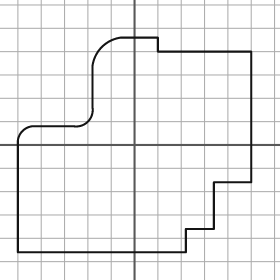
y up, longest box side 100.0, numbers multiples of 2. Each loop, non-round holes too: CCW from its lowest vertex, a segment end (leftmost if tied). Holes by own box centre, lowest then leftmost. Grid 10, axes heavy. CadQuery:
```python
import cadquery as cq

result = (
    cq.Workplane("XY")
    .moveTo(-50.0, -46.0)
    .lineTo(22.0, -46.0)
    .lineTo(22.0, -36.0)
    .lineTo(34.0, -36.0)
    .lineTo(34.0, -16.0)
    .lineTo(50.0, -16.0)
    .lineTo(50.0, 40.0)
    .lineTo(10.0, 40.0)
    .lineTo(10.0, 46.0)
    .lineTo(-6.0, 46.0)
    .threePointArc((-14.0, 42.0), (-18.0, 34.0))
    .lineTo(-18.0, 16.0)
    .threePointArc((-20.0, 10.0), (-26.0, 8.0))
    .lineTo(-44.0, 8.0)
    .threePointArc((-48.0, 6.0), (-50.0, 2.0))
    .close()
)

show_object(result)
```